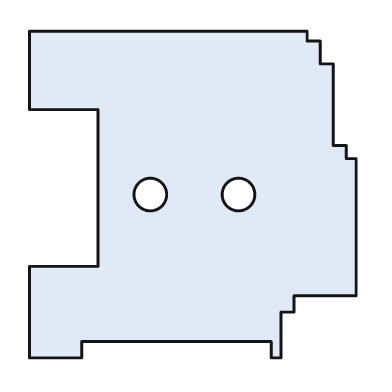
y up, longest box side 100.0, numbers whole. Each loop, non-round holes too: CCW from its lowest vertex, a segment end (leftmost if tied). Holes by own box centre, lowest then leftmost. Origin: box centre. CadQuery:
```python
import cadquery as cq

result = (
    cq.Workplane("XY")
    .moveTo(-50.0, -50.0)
    .lineTo(-34.0, -50.0)
    .lineTo(-34.0, -45.0)
    .lineTo(24.0, -45.0)
    .lineTo(24.0, -50.0)
    .lineTo(27.0, -50.0)
    .lineTo(27.0, -36.0)
    .lineTo(31.0, -36.0)
    .lineTo(31.0, -31.0)
    .lineTo(50.0, -31.0)
    .lineTo(50.0, 11.0)
    .lineTo(47.0, 11.0)
    .lineTo(47.0, 15.0)
    .lineTo(43.0, 15.0)
    .lineTo(43.0, 40.0)
    .lineTo(39.0, 40.0)
    .lineTo(39.0, 47.0)
    .lineTo(35.0, 47.0)
    .lineTo(35.0, 50.0)
    .lineTo(-50.0, 50.0)
    .lineTo(-50.0, 26.0)
    .lineTo(-29.0, 26.0)
    .lineTo(-29.0, -22.0)
    .lineTo(-50.0, -22.0)
    .close()
    .moveTo(-13.0, 0.0)
    .circle(5.0)
    .moveTo(14.0, 0.0)
    .circle(5.0)
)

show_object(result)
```